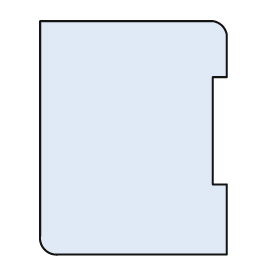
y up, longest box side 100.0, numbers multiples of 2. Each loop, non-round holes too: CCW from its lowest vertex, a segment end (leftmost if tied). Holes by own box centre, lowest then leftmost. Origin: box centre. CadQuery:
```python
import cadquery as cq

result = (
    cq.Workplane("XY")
    .moveTo(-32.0, -50.0)
    .lineTo(40.0, -50.0)
    .lineTo(40.0, -20.0)
    .lineTo(34.0, -20.0)
    .lineTo(34.0, 26.0)
    .lineTo(40.0, 26.0)
    .lineTo(40.0, 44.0)
    .threePointArc((38.0, 48.0), (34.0, 50.0))
    .lineTo(-40.0, 50.0)
    .lineTo(-40.0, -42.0)
    .threePointArc((-38.0, -48.0), (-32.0, -50.0))
    .close()
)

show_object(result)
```